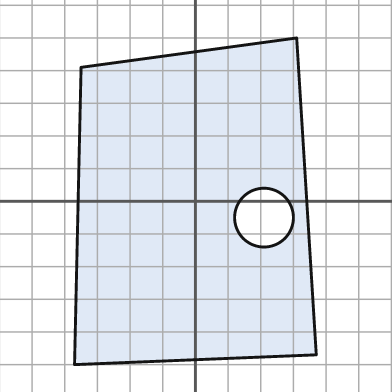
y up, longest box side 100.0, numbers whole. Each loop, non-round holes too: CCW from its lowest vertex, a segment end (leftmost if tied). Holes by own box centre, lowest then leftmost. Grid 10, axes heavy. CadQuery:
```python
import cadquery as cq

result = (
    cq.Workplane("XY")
    .moveTo(-37.0, -50.0)
    .lineTo(37.0, -47.0)
    .lineTo(31.0, 50.0)
    .lineTo(-35.0, 41.0)
    .close()
    .moveTo(21.0, -5.0)
    .circle(9.0)
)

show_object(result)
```